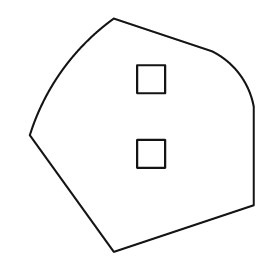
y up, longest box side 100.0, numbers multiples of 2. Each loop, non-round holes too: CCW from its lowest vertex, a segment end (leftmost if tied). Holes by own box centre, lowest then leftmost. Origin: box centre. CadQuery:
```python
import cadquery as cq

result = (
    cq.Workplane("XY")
    .moveTo(-12.0, -50.0)
    .lineTo(48.0, -30.0)
    .lineTo(48.0, 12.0)
    .threePointArc((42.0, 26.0), (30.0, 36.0))
    .lineTo(-12.0, 50.0)
    .threePointArc((-34.0, 28.0), (-48.0, 0.0))
    .close()
    .moveTo(-2.0, -14.0)
    .lineTo(10.0, -14.0)
    .lineTo(10.0, -2.0)
    .lineTo(-2.0, -2.0)
    .close()
    .moveTo(-2.0, 18.0)
    .lineTo(10.0, 18.0)
    .lineTo(10.0, 30.0)
    .lineTo(-2.0, 30.0)
    .close()
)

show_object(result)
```